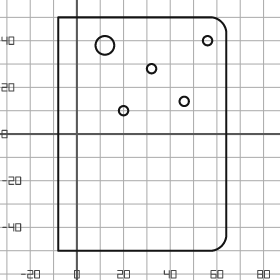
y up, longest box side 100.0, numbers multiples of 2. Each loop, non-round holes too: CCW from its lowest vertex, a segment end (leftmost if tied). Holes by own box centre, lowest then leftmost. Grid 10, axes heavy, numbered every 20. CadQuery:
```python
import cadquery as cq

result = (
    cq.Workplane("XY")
    .moveTo(-8.0, -50.0)
    .lineTo(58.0, -50.0)
    .threePointArc((62.0, -48.0), (64.0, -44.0))
    .lineTo(64.0, 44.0)
    .threePointArc((62.0, 48.0), (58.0, 50.0))
    .lineTo(-8.0, 50.0)
    .close()
    .moveTo(20.0, 10.0)
    .circle(2.0)
    .moveTo(46.0, 14.0)
    .circle(2.0)
    .moveTo(32.0, 28.0)
    .circle(2.0)
    .moveTo(12.0, 38.0)
    .circle(4.0)
    .moveTo(56.0, 40.0)
    .circle(2.0)
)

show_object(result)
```